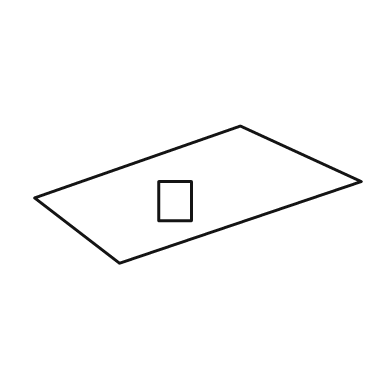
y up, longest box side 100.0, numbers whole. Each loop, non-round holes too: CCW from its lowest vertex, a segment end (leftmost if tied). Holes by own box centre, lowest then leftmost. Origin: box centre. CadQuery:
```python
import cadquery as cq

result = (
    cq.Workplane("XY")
    .moveTo(-24.0, -21.0)
    .lineTo(50.0, 4.0)
    .lineTo(13.0, 21.0)
    .lineTo(-50.0, -1.0)
    .close()
    .moveTo(-12.0, -8.0)
    .lineTo(-2.0, -8.0)
    .lineTo(-2.0, 4.0)
    .lineTo(-12.0, 4.0)
    .close()
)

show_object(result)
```